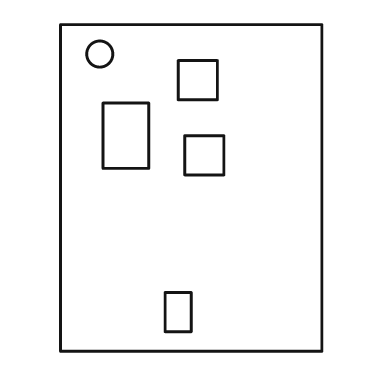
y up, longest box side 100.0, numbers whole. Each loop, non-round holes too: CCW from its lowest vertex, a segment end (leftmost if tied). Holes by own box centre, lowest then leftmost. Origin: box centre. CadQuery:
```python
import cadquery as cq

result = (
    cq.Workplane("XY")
    .moveTo(-40.0, -50.0)
    .lineTo(40.0, -50.0)
    .lineTo(40.0, 50.0)
    .lineTo(-40.0, 50.0)
    .close()
    .moveTo(-8.0, -44.0)
    .lineTo(0.0, -44.0)
    .lineTo(0.0, -32.0)
    .lineTo(-8.0, -32.0)
    .close()
    .moveTo(-2.0, 4.0)
    .lineTo(10.0, 4.0)
    .lineTo(10.0, 16.0)
    .lineTo(-2.0, 16.0)
    .close()
    .moveTo(-27.0, 6.0)
    .lineTo(-13.0, 6.0)
    .lineTo(-13.0, 26.0)
    .lineTo(-27.0, 26.0)
    .close()
    .moveTo(-4.0, 27.0)
    .lineTo(8.0, 27.0)
    .lineTo(8.0, 39.0)
    .lineTo(-4.0, 39.0)
    .close()
    .moveTo(-28.0, 41.0)
    .circle(4.0)
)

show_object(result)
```